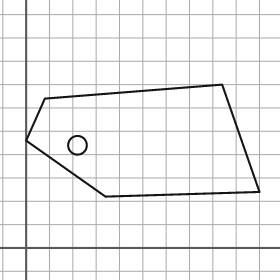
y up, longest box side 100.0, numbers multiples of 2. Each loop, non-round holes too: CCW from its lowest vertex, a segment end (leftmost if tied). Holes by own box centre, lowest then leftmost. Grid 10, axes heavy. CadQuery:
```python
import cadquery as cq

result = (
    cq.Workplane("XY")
    .moveTo(34.0, 22.0)
    .lineTo(100.0, 24.0)
    .lineTo(84.0, 70.0)
    .lineTo(8.0, 64.0)
    .lineTo(0.0, 46.0)
    .close()
    .moveTo(22.0, 44.0)
    .circle(4.0)
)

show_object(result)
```